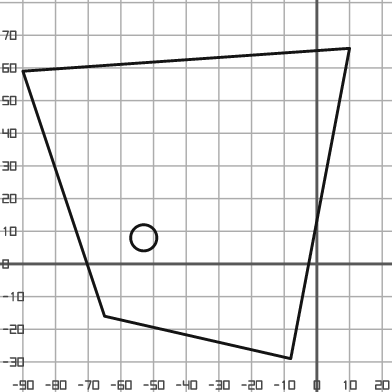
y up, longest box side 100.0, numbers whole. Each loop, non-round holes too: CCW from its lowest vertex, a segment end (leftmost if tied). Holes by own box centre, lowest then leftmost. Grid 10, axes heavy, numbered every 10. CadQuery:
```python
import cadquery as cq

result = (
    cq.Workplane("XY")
    .moveTo(-8.0, -29.0)
    .lineTo(10.0, 66.0)
    .lineTo(-90.0, 59.0)
    .lineTo(-65.0, -16.0)
    .close()
    .moveTo(-53.0, 8.0)
    .circle(4.0)
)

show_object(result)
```